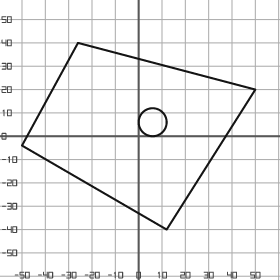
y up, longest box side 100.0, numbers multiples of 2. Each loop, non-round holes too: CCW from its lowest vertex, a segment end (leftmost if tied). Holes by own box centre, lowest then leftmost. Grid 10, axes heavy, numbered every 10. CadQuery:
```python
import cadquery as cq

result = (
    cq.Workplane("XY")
    .moveTo(12.0, -40.0)
    .lineTo(50.0, 20.0)
    .lineTo(-26.0, 40.0)
    .lineTo(-50.0, -4.0)
    .close()
    .moveTo(6.0, 6.0)
    .circle(6.0)
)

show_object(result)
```